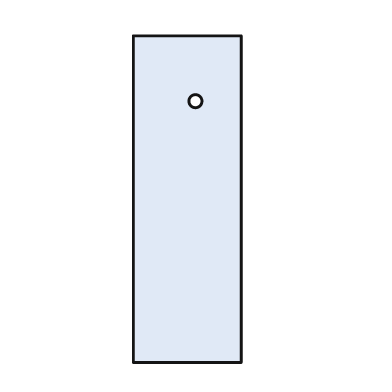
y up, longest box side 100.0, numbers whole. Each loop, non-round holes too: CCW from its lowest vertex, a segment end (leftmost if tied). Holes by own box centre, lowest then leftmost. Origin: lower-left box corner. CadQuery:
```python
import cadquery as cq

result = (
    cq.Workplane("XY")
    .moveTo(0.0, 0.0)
    .lineTo(33.0, 0.0)
    .lineTo(33.0, 100.0)
    .lineTo(0.0, 100.0)
    .close()
    .moveTo(19.0, 80.0)
    .circle(2.0)
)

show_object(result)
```